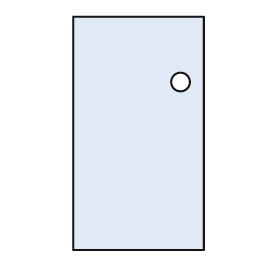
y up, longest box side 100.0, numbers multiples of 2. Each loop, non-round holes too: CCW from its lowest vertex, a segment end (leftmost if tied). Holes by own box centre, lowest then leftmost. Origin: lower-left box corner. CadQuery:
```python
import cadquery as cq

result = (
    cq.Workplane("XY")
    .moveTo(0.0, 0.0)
    .lineTo(56.0, 0.0)
    .lineTo(56.0, 100.0)
    .lineTo(0.0, 100.0)
    .close()
    .moveTo(46.0, 72.0)
    .circle(4.0)
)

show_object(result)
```